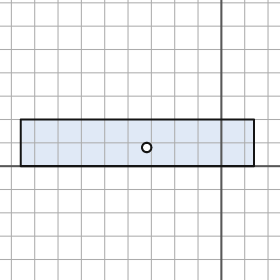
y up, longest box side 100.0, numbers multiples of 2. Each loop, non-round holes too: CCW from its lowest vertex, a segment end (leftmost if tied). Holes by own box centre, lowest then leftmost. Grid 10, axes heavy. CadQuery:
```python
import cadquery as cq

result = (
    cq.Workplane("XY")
    .moveTo(-86.0, 0.0)
    .lineTo(14.0, 0.0)
    .lineTo(14.0, 20.0)
    .lineTo(-86.0, 20.0)
    .close()
    .moveTo(-32.0, 8.0)
    .circle(2.0)
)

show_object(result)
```